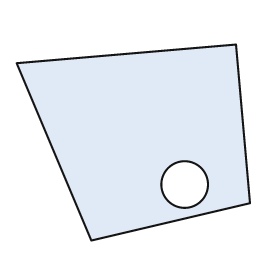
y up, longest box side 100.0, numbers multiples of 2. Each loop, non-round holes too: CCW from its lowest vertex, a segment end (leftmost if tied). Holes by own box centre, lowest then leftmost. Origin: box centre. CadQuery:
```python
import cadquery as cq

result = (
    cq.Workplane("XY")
    .moveTo(-18.0, -42.0)
    .lineTo(50.0, -26.0)
    .lineTo(44.0, 42.0)
    .lineTo(-50.0, 34.0)
    .close()
    .moveTo(22.0, -18.0)
    .circle(10.0)
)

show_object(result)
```